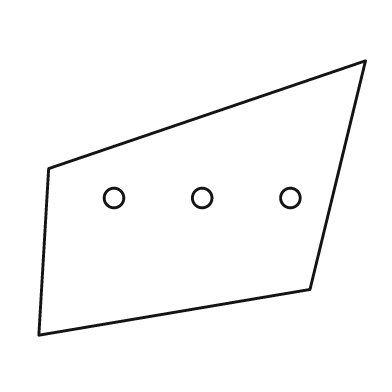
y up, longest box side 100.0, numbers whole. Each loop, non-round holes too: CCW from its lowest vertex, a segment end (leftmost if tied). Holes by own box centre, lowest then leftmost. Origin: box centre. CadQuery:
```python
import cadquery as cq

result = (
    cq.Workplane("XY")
    .moveTo(-50.0, -42.0)
    .lineTo(33.0, -28.0)
    .lineTo(50.0, 42.0)
    .lineTo(-47.0, 9.0)
    .close()
    .moveTo(-27.0, 0.0)
    .circle(3.0)
    .moveTo(0.0, 0.0)
    .circle(3.0)
    .moveTo(27.0, 0.0)
    .circle(3.0)
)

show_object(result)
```